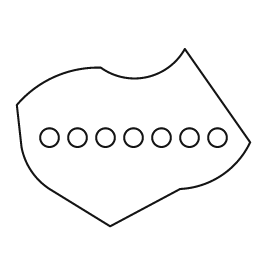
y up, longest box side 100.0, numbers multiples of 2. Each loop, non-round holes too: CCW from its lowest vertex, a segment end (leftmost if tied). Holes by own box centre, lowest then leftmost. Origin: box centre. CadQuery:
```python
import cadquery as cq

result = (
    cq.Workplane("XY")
    .moveTo(-10.0, -38.0)
    .lineTo(20.0, -22.0)
    .threePointArc((38.0, -16.0), (50.0, -2.0))
    .lineTo(22.0, 38.0)
    .threePointArc((6.0, 26.0), (-14.0, 30.0))
    .threePointArc((-34.0, 26.0), (-50.0, 14.0))
    .lineTo(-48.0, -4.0)
    .threePointArc((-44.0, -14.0), (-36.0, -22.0))
    .close()
    .moveTo(-36.0, 0.0)
    .circle(4.0)
    .moveTo(-24.0, 0.0)
    .circle(4.0)
    .moveTo(-12.0, 0.0)
    .circle(4.0)
    .moveTo(0.0, 0.0)
    .circle(4.0)
    .moveTo(12.0, 0.0)
    .circle(4.0)
    .moveTo(24.0, 0.0)
    .circle(4.0)
    .moveTo(36.0, 0.0)
    .circle(4.0)
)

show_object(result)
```